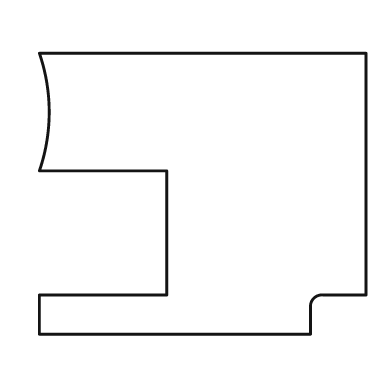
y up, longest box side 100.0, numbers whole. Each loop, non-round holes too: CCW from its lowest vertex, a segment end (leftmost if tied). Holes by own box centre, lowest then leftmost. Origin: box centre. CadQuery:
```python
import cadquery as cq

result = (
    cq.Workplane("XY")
    .moveTo(-50.0, -43.0)
    .lineTo(33.0, -43.0)
    .lineTo(33.0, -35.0)
    .threePointArc((34.0, -32.0), (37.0, -31.0))
    .lineTo(50.0, -31.0)
    .lineTo(50.0, 43.0)
    .lineTo(-50.0, 43.0)
    .threePointArc((-47.0, 25.0), (-50.0, 7.0))
    .lineTo(-11.0, 7.0)
    .lineTo(-11.0, -31.0)
    .lineTo(-50.0, -31.0)
    .close()
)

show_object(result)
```